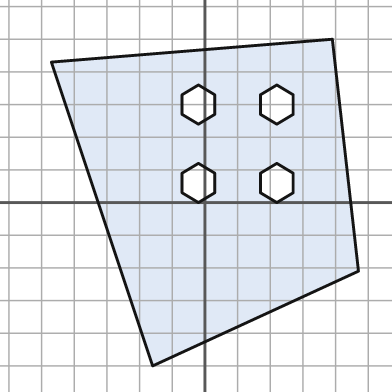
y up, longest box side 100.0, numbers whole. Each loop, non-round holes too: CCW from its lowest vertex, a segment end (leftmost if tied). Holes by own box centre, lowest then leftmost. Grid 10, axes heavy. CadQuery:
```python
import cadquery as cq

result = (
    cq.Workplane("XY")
    .moveTo(-16.0, -50.0)
    .lineTo(47.0, -21.0)
    .lineTo(39.0, 50.0)
    .lineTo(-47.0, 43.0)
    .close()
    .moveTo(-2.0, 0.0)
    .lineTo(3.0, 3.0)
    .lineTo(3.0, 9.0)
    .lineTo(-2.0, 12.0)
    .lineTo(-7.0, 9.0)
    .lineTo(-7.0, 3.0)
    .close()
    .moveTo(22.0, 0.0)
    .lineTo(27.0, 3.0)
    .lineTo(27.0, 9.0)
    .lineTo(22.0, 12.0)
    .lineTo(17.0, 9.0)
    .lineTo(17.0, 3.0)
    .close()
    .moveTo(-2.0, 24.0)
    .lineTo(3.0, 27.0)
    .lineTo(3.0, 33.0)
    .lineTo(-2.0, 36.0)
    .lineTo(-7.0, 33.0)
    .lineTo(-7.0, 27.0)
    .close()
    .moveTo(22.0, 24.0)
    .lineTo(27.0, 27.0)
    .lineTo(27.0, 33.0)
    .lineTo(22.0, 36.0)
    .lineTo(17.0, 33.0)
    .lineTo(17.0, 27.0)
    .close()
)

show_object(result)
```